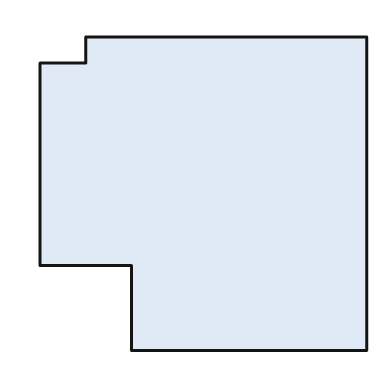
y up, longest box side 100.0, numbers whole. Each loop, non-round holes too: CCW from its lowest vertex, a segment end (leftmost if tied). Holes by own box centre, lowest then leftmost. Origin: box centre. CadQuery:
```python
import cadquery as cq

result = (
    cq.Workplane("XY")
    .moveTo(-22.0, -48.0)
    .lineTo(50.0, -48.0)
    .lineTo(50.0, 48.0)
    .lineTo(-36.0, 48.0)
    .lineTo(-36.0, 40.0)
    .lineTo(-50.0, 40.0)
    .lineTo(-50.0, -22.0)
    .lineTo(-22.0, -22.0)
    .close()
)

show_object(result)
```